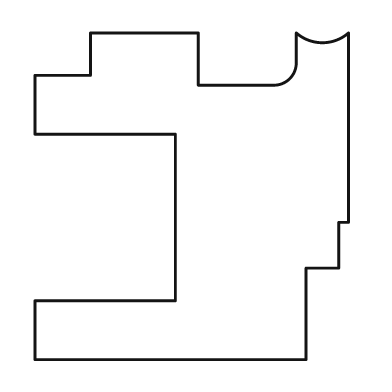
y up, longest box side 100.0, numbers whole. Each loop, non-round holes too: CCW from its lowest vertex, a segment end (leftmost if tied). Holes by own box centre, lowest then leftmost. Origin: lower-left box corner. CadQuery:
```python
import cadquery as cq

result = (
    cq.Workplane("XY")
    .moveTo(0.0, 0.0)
    .lineTo(83.0, 0.0)
    .lineTo(83.0, 28.0)
    .lineTo(93.0, 28.0)
    .lineTo(93.0, 42.0)
    .lineTo(96.0, 42.0)
    .lineTo(96.0, 100.0)
    .threePointArc((88.0, 97.0), (80.0, 100.0))
    .lineTo(80.0, 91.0)
    .threePointArc((78.0, 86.0), (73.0, 84.0))
    .lineTo(50.0, 84.0)
    .lineTo(50.0, 100.0)
    .lineTo(17.0, 100.0)
    .lineTo(17.0, 87.0)
    .lineTo(0.0, 87.0)
    .lineTo(0.0, 69.0)
    .lineTo(43.0, 69.0)
    .lineTo(43.0, 18.0)
    .lineTo(0.0, 18.0)
    .close()
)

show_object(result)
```